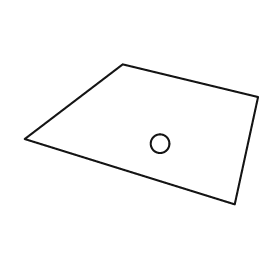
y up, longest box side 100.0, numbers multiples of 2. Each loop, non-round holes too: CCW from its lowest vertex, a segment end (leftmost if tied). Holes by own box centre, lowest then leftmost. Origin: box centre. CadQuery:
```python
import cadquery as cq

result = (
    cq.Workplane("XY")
    .moveTo(40.0, -30.0)
    .lineTo(50.0, 16.0)
    .lineTo(-8.0, 30.0)
    .lineTo(-50.0, -2.0)
    .close()
    .moveTo(8.0, -4.0)
    .circle(4.0)
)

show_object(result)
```